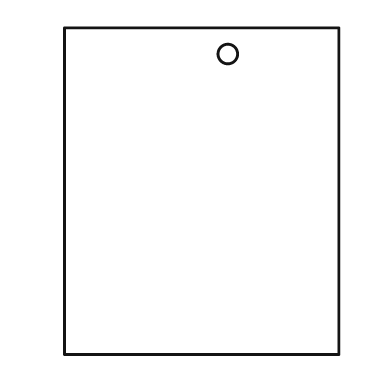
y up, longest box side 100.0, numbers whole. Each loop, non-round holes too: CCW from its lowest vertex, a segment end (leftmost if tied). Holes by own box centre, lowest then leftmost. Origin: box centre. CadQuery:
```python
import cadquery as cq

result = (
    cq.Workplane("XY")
    .moveTo(-42.0, -50.0)
    .lineTo(42.0, -50.0)
    .lineTo(42.0, 50.0)
    .lineTo(-42.0, 50.0)
    .close()
    .moveTo(8.0, 42.0)
    .circle(3.0)
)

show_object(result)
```